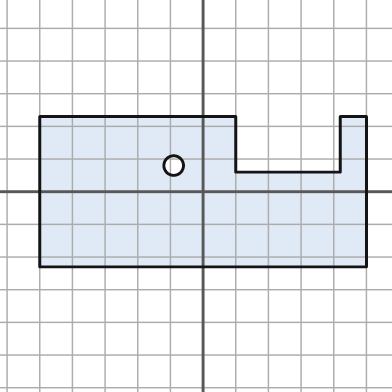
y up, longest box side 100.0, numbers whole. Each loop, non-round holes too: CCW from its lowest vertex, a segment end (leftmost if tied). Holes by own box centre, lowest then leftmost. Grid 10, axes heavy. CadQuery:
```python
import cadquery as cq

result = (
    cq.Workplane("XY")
    .moveTo(-50.0, -23.0)
    .lineTo(50.0, -23.0)
    .lineTo(50.0, 23.0)
    .lineTo(42.0, 23.0)
    .lineTo(42.0, 6.0)
    .lineTo(10.0, 6.0)
    .lineTo(10.0, 23.0)
    .lineTo(-50.0, 23.0)
    .close()
    .moveTo(-9.0, 8.0)
    .circle(3.0)
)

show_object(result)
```